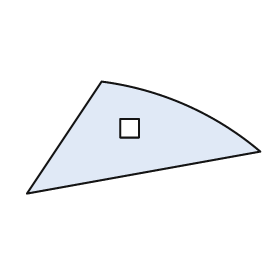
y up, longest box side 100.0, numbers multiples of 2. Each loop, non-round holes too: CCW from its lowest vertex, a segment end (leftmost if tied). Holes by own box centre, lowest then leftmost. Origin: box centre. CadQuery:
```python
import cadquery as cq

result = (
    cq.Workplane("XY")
    .moveTo(-50.0, -24.0)
    .lineTo(50.0, -6.0)
    .threePointArc((18.0, 14.0), (-18.0, 24.0))
    .close()
    .moveTo(-10.0, 0.0)
    .lineTo(-2.0, 0.0)
    .lineTo(-2.0, 8.0)
    .lineTo(-10.0, 8.0)
    .close()
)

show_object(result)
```